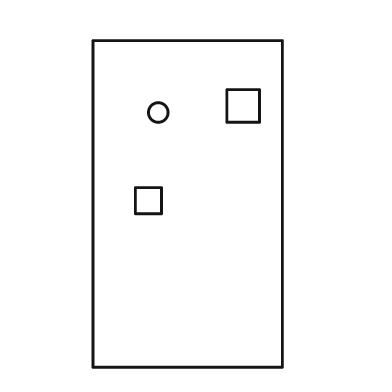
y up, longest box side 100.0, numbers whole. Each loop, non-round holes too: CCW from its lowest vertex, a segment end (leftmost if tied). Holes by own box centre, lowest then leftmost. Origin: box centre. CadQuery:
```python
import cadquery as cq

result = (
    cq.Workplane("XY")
    .moveTo(-29.0, -50.0)
    .lineTo(29.0, -50.0)
    .lineTo(29.0, 50.0)
    .lineTo(-29.0, 50.0)
    .close()
    .moveTo(-16.0, -3.0)
    .lineTo(-8.0, -3.0)
    .lineTo(-8.0, 5.0)
    .lineTo(-16.0, 5.0)
    .close()
    .moveTo(-9.0, 28.0)
    .circle(3.0)
    .moveTo(12.0, 25.0)
    .lineTo(22.0, 25.0)
    .lineTo(22.0, 35.0)
    .lineTo(12.0, 35.0)
    .close()
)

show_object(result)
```